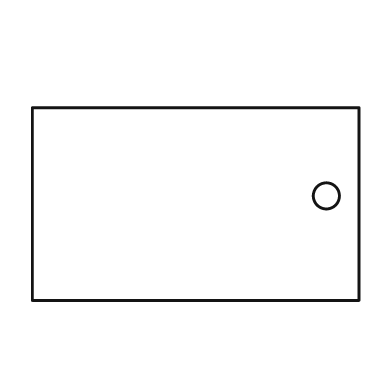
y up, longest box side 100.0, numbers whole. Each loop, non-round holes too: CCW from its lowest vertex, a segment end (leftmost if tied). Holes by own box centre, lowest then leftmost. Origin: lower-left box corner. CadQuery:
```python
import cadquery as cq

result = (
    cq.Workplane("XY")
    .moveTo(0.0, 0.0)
    .lineTo(100.0, 0.0)
    .lineTo(100.0, 59.0)
    .lineTo(0.0, 59.0)
    .close()
    .moveTo(90.0, 32.0)
    .circle(4.0)
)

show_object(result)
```